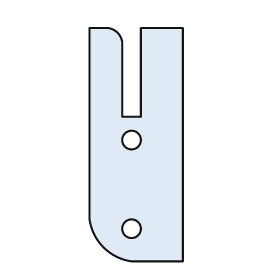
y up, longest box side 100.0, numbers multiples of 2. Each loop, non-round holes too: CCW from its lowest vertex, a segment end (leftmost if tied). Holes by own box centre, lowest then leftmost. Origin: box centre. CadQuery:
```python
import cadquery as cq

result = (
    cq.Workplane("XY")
    .moveTo(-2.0, -50.0)
    .lineTo(20.0, -50.0)
    .lineTo(20.0, 50.0)
    .lineTo(2.0, 50.0)
    .lineTo(2.0, 12.0)
    .lineTo(-6.0, 12.0)
    .lineTo(-6.0, 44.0)
    .threePointArc((-8.0, 48.0), (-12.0, 50.0))
    .lineTo(-20.0, 50.0)
    .lineTo(-20.0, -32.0)
    .threePointArc((-14.0, -44.0), (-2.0, -50.0))
    .close()
    .moveTo(-2.0, -36.0)
    .circle(4.0)
    .moveTo(-2.0, 2.0)
    .circle(4.0)
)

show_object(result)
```